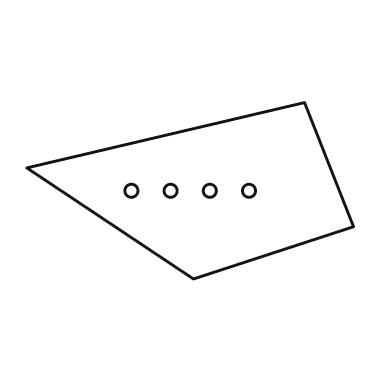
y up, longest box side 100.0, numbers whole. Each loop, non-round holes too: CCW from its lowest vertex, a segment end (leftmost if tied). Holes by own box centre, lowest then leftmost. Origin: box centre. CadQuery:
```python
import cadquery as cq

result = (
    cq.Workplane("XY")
    .moveTo(1.0, -27.0)
    .lineTo(50.0, -11.0)
    .lineTo(35.0, 27.0)
    .lineTo(-50.0, 7.0)
    .close()
    .moveTo(-18.0, 0.0)
    .circle(2.0)
    .moveTo(-6.0, 0.0)
    .circle(2.0)
    .moveTo(6.0, 0.0)
    .circle(2.0)
    .moveTo(18.0, 0.0)
    .circle(2.0)
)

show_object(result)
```